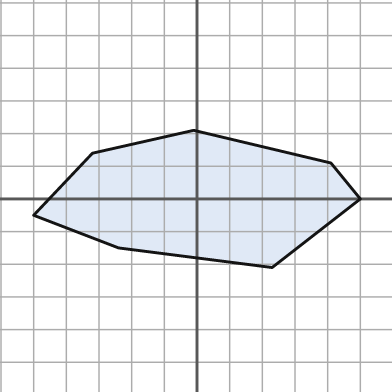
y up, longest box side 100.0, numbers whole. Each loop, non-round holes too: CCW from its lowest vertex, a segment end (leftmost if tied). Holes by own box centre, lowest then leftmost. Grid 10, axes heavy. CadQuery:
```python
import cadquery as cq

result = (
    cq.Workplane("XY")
    .moveTo(23.0, -21.0)
    .lineTo(50.0, 0.0)
    .lineTo(41.0, 11.0)
    .lineTo(-1.0, 21.0)
    .lineTo(-32.0, 14.0)
    .lineTo(-50.0, -5.0)
    .lineTo(-24.0, -15.0)
    .close()
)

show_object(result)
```